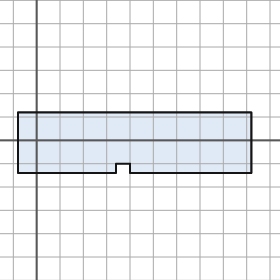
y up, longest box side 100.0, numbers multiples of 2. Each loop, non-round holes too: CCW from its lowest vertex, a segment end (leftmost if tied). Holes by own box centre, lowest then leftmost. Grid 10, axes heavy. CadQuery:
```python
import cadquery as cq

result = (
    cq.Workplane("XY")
    .moveTo(-8.0, -14.0)
    .lineTo(34.0, -14.0)
    .lineTo(34.0, -10.0)
    .lineTo(40.0, -10.0)
    .lineTo(40.0, -14.0)
    .lineTo(92.0, -14.0)
    .lineTo(92.0, 12.0)
    .lineTo(-8.0, 12.0)
    .close()
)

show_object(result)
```